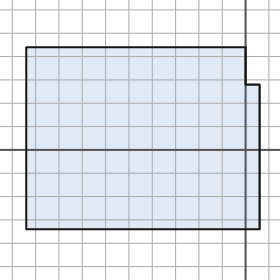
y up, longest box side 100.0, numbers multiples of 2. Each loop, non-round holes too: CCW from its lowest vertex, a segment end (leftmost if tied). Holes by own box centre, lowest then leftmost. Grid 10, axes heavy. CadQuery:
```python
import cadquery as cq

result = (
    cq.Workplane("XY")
    .moveTo(-94.0, -34.0)
    .lineTo(6.0, -34.0)
    .lineTo(6.0, 28.0)
    .lineTo(0.0, 28.0)
    .lineTo(0.0, 44.0)
    .lineTo(-94.0, 44.0)
    .close()
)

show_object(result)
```